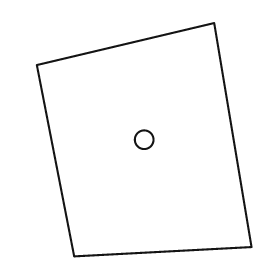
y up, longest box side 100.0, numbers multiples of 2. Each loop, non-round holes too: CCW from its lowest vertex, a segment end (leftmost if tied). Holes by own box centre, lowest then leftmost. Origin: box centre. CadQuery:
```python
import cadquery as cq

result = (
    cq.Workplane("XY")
    .moveTo(-30.0, -50.0)
    .lineTo(46.0, -46.0)
    .lineTo(30.0, 50.0)
    .lineTo(-46.0, 32.0)
    .close()
    .moveTo(0.0, 0.0)
    .circle(4.0)
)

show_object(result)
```